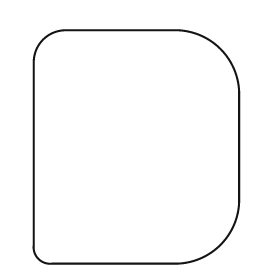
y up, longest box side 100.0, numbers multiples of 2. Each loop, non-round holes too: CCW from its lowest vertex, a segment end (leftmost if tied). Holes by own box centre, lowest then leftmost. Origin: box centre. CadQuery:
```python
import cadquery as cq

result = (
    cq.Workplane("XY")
    .moveTo(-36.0, -50.0)
    .lineTo(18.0, -50.0)
    .threePointArc((36.0, -42.0), (44.0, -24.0))
    .lineTo(44.0, 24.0)
    .threePointArc((36.0, 42.0), (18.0, 50.0))
    .lineTo(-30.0, 50.0)
    .threePointArc((-40.0, 46.0), (-44.0, 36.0))
    .lineTo(-44.0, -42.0)
    .threePointArc((-42.0, -48.0), (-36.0, -50.0))
    .close()
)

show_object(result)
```